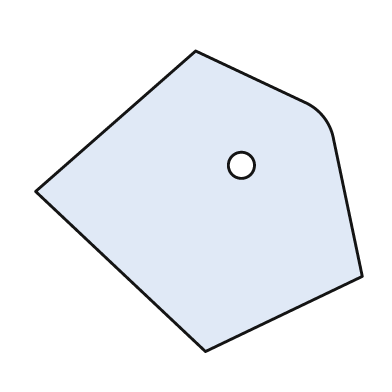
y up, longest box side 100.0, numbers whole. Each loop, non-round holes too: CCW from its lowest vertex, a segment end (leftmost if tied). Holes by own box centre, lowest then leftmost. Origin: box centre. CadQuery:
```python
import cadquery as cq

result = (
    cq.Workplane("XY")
    .moveTo(2.0, -46.0)
    .lineTo(50.0, -23.0)
    .lineTo(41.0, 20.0)
    .threePointArc((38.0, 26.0), (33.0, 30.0))
    .lineTo(-1.0, 46.0)
    .lineTo(-50.0, 3.0)
    .close()
    .moveTo(13.0, 11.0)
    .circle(4.0)
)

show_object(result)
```